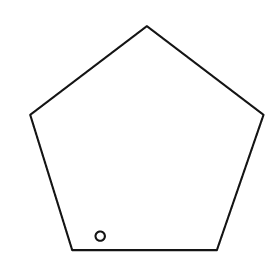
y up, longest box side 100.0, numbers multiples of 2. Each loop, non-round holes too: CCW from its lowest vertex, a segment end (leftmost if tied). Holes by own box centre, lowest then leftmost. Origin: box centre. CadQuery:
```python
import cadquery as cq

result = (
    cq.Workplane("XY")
    .moveTo(-32.0, -48.0)
    .lineTo(30.0, -48.0)
    .lineTo(50.0, 10.0)
    .lineTo(0.0, 48.0)
    .lineTo(-50.0, 10.0)
    .close()
    .moveTo(-20.0, -42.0)
    .circle(2.0)
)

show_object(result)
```